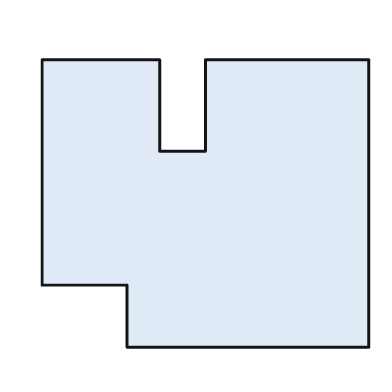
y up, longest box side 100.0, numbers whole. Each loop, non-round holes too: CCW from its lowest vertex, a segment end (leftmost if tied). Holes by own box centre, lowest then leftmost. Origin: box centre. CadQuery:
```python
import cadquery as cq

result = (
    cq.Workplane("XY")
    .moveTo(-24.0, -44.0)
    .lineTo(50.0, -44.0)
    .lineTo(50.0, 44.0)
    .lineTo(0.0, 44.0)
    .lineTo(0.0, 16.0)
    .lineTo(-14.0, 16.0)
    .lineTo(-14.0, 44.0)
    .lineTo(-50.0, 44.0)
    .lineTo(-50.0, -25.0)
    .lineTo(-24.0, -25.0)
    .close()
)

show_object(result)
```